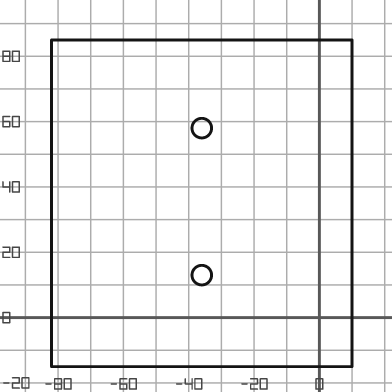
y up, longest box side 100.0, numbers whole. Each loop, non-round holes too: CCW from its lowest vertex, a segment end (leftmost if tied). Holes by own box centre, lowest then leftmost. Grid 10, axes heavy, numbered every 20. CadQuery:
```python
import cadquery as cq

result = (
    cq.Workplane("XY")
    .moveTo(-82.0, -15.0)
    .lineTo(10.0, -15.0)
    .lineTo(10.0, 85.0)
    .lineTo(-82.0, 85.0)
    .close()
    .moveTo(-36.0, 13.0)
    .circle(3.0)
    .moveTo(-36.0, 58.0)
    .circle(3.0)
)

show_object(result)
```